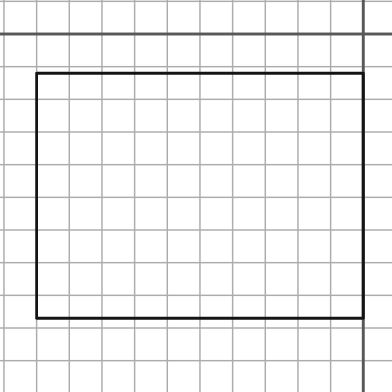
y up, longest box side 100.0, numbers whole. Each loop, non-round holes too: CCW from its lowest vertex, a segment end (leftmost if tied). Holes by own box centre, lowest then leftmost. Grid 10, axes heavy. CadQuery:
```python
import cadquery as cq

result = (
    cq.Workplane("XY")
    .moveTo(-100.0, -87.0)
    .lineTo(0.0, -87.0)
    .lineTo(0.0, -12.0)
    .lineTo(-100.0, -12.0)
    .close()
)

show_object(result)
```